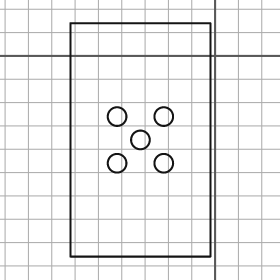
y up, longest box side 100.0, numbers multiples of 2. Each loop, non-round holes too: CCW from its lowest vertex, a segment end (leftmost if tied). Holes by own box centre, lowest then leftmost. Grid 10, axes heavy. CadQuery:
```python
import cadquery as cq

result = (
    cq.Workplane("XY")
    .moveTo(-62.0, -86.0)
    .lineTo(-2.0, -86.0)
    .lineTo(-2.0, 14.0)
    .lineTo(-62.0, 14.0)
    .close()
    .moveTo(-42.0, -46.0)
    .circle(4.0)
    .moveTo(-22.0, -46.0)
    .circle(4.0)
    .moveTo(-32.0, -36.0)
    .circle(4.0)
    .moveTo(-42.0, -26.0)
    .circle(4.0)
    .moveTo(-22.0, -26.0)
    .circle(4.0)
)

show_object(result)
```